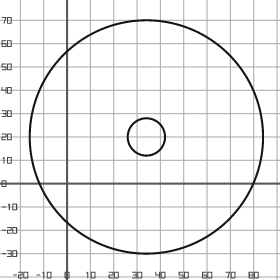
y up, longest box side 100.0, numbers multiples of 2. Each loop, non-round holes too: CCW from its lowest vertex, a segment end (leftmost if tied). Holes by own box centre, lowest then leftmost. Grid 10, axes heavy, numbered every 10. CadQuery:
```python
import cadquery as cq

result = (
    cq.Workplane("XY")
    .moveTo(34.0, 20.0)
    .circle(50.0)
    .moveTo(34.0, 20.0)
    .circle(8.0)
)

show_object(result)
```